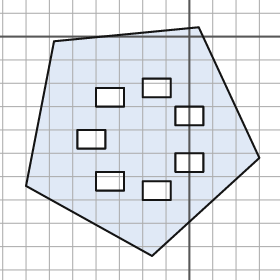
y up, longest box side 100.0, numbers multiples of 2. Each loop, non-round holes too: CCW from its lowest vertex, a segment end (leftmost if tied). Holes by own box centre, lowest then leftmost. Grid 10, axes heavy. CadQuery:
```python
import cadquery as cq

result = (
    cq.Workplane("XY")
    .moveTo(-16.0, -94.0)
    .lineTo(30.0, -52.0)
    .lineTo(4.0, 4.0)
    .lineTo(-58.0, -2.0)
    .lineTo(-70.0, -64.0)
    .close()
    .moveTo(-20.0, -70.0)
    .lineTo(-8.0, -70.0)
    .lineTo(-8.0, -62.0)
    .lineTo(-20.0, -62.0)
    .close()
    .moveTo(-40.0, -66.0)
    .lineTo(-28.0, -66.0)
    .lineTo(-28.0, -58.0)
    .lineTo(-40.0, -58.0)
    .close()
    .moveTo(-6.0, -58.0)
    .lineTo(6.0, -58.0)
    .lineTo(6.0, -50.0)
    .lineTo(-6.0, -50.0)
    .close()
    .moveTo(-48.0, -48.0)
    .lineTo(-36.0, -48.0)
    .lineTo(-36.0, -40.0)
    .lineTo(-48.0, -40.0)
    .close()
    .moveTo(-6.0, -38.0)
    .lineTo(6.0, -38.0)
    .lineTo(6.0, -30.0)
    .lineTo(-6.0, -30.0)
    .close()
    .moveTo(-40.0, -30.0)
    .lineTo(-28.0, -30.0)
    .lineTo(-28.0, -22.0)
    .lineTo(-40.0, -22.0)
    .close()
    .moveTo(-20.0, -26.0)
    .lineTo(-8.0, -26.0)
    .lineTo(-8.0, -18.0)
    .lineTo(-20.0, -18.0)
    .close()
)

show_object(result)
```